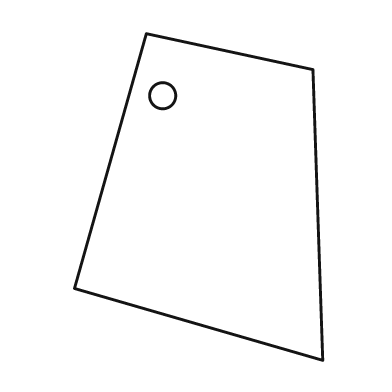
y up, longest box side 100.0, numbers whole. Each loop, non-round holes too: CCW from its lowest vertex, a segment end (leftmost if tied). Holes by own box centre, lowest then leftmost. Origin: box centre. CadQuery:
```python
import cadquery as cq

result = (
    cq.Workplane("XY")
    .moveTo(38.0, -50.0)
    .lineTo(35.0, 39.0)
    .lineTo(-16.0, 50.0)
    .lineTo(-38.0, -28.0)
    .close()
    .moveTo(-11.0, 31.0)
    .circle(4.0)
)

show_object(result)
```